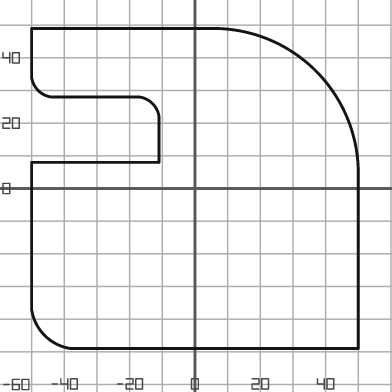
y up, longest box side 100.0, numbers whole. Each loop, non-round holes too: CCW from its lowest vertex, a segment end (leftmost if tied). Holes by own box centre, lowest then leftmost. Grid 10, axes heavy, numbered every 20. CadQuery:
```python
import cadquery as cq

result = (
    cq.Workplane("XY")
    .moveTo(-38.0, -49.0)
    .lineTo(50.0, -49.0)
    .lineTo(50.0, 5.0)
    .threePointArc((37.0, 36.0), (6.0, 49.0))
    .lineTo(-50.0, 49.0)
    .lineTo(-50.0, 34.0)
    .threePointArc((-48.0, 30.0), (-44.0, 28.0))
    .lineTo(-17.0, 28.0)
    .threePointArc((-13.0, 26.0), (-11.0, 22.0))
    .lineTo(-11.0, 8.0)
    .lineTo(-50.0, 8.0)
    .lineTo(-50.0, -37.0)
    .threePointArc((-46.0, -45.0), (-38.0, -49.0))
    .close()
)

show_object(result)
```